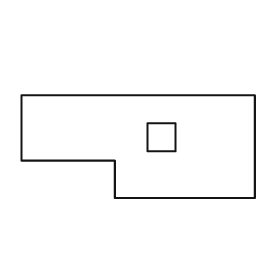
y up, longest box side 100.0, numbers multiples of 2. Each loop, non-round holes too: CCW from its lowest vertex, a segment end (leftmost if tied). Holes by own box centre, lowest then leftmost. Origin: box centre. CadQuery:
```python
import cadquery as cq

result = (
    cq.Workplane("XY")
    .moveTo(-10.0, -22.0)
    .lineTo(50.0, -22.0)
    .lineTo(50.0, 22.0)
    .lineTo(-50.0, 22.0)
    .lineTo(-50.0, -6.0)
    .lineTo(-10.0, -6.0)
    .close()
    .moveTo(4.0, -2.0)
    .lineTo(16.0, -2.0)
    .lineTo(16.0, 10.0)
    .lineTo(4.0, 10.0)
    .close()
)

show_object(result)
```